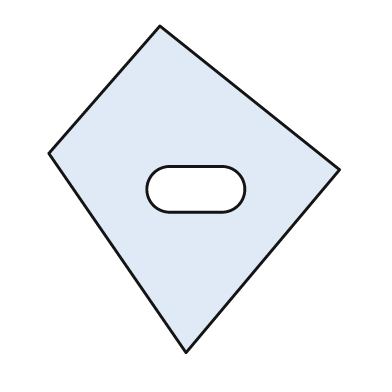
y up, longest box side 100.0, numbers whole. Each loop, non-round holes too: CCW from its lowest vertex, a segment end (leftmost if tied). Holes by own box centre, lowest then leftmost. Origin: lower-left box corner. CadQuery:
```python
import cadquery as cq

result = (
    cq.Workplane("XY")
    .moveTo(42.0, 0.0)
    .lineTo(89.0, 56.0)
    .lineTo(34.0, 100.0)
    .lineTo(0.0, 61.0)
    .close()
    .moveTo(37.0, 43.0)
    .lineTo(53.0, 43.0)
    .threePointArc((60.0, 50.0), (53.0, 57.0))
    .lineTo(37.0, 57.0)
    .threePointArc((30.0, 50.0), (37.0, 43.0))
    .close()
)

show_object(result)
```